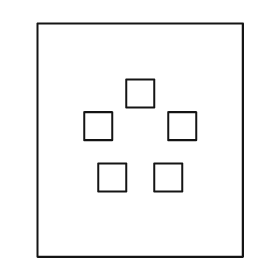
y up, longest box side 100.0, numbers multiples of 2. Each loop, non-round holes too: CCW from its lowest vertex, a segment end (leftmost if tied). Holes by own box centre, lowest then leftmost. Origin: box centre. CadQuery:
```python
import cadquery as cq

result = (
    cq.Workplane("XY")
    .moveTo(-44.0, -50.0)
    .lineTo(44.0, -50.0)
    .lineTo(44.0, 50.0)
    .lineTo(-44.0, 50.0)
    .close()
    .moveTo(-18.0, -22.0)
    .lineTo(-6.0, -22.0)
    .lineTo(-6.0, -10.0)
    .lineTo(-18.0, -10.0)
    .close()
    .moveTo(6.0, -22.0)
    .lineTo(18.0, -22.0)
    .lineTo(18.0, -10.0)
    .lineTo(6.0, -10.0)
    .close()
    .moveTo(-24.0, 0.0)
    .lineTo(-12.0, 0.0)
    .lineTo(-12.0, 12.0)
    .lineTo(-24.0, 12.0)
    .close()
    .moveTo(12.0, 0.0)
    .lineTo(24.0, 0.0)
    .lineTo(24.0, 12.0)
    .lineTo(12.0, 12.0)
    .close()
    .moveTo(-6.0, 14.0)
    .lineTo(6.0, 14.0)
    .lineTo(6.0, 26.0)
    .lineTo(-6.0, 26.0)
    .close()
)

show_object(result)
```